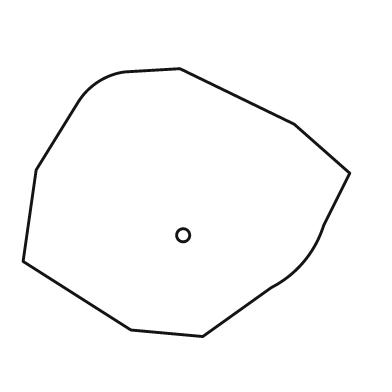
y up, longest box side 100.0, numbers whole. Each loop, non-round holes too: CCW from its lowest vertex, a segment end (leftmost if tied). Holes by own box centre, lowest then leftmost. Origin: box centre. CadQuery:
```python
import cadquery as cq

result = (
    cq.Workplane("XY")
    .moveTo(5.0, -41.0)
    .lineTo(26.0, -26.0)
    .threePointArc((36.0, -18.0), (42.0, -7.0))
    .lineTo(50.0, 9.0)
    .lineTo(33.0, 24.0)
    .lineTo(-2.0, 41.0)
    .lineTo(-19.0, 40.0)
    .threePointArc((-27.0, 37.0), (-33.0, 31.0))
    .lineTo(-46.0, 10.0)
    .lineTo(-50.0, -18.0)
    .lineTo(-17.0, -39.0)
    .close()
    .moveTo(-1.0, -10.0)
    .circle(2.0)
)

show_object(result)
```